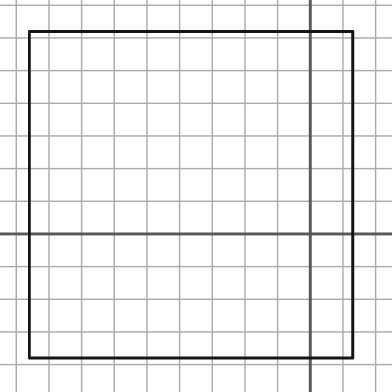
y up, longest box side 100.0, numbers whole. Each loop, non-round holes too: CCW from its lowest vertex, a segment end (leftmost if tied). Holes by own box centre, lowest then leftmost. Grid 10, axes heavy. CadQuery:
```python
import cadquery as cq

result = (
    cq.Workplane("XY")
    .moveTo(-86.0, -38.0)
    .lineTo(13.0, -38.0)
    .lineTo(13.0, 62.0)
    .lineTo(-86.0, 62.0)
    .close()
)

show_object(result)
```